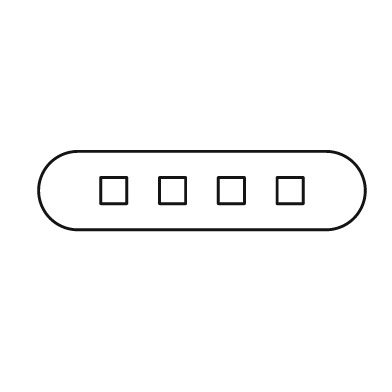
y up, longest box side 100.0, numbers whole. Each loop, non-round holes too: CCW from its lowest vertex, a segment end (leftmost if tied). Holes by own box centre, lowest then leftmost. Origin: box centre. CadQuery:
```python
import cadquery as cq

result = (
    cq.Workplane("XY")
    .moveTo(-38.0, -12.0)
    .lineTo(38.0, -12.0)
    .threePointArc((50.0, 0.0), (38.0, 12.0))
    .lineTo(-38.0, 12.0)
    .threePointArc((-50.0, 0.0), (-38.0, -12.0))
    .close()
    .moveTo(-31.0, -4.0)
    .lineTo(-23.0, -4.0)
    .lineTo(-23.0, 4.0)
    .lineTo(-31.0, 4.0)
    .close()
    .moveTo(-13.0, -4.0)
    .lineTo(-5.0, -4.0)
    .lineTo(-5.0, 4.0)
    .lineTo(-13.0, 4.0)
    .close()
    .moveTo(5.0, -4.0)
    .lineTo(13.0, -4.0)
    .lineTo(13.0, 4.0)
    .lineTo(5.0, 4.0)
    .close()
    .moveTo(23.0, -4.0)
    .lineTo(31.0, -4.0)
    .lineTo(31.0, 4.0)
    .lineTo(23.0, 4.0)
    .close()
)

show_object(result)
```